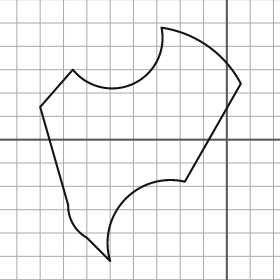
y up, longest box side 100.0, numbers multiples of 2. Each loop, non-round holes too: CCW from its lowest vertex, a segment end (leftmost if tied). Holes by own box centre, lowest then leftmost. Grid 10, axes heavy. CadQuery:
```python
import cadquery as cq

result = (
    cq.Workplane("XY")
    .moveTo(-50.0, -52.0)
    .threePointArc((-44.0, -26.0), (-18.0, -18.0))
    .lineTo(6.0, 24.0)
    .threePointArc((-8.0, 40.0), (-28.0, 48.0))
    .threePointArc((-40.0, 24.0), (-66.0, 30.0))
    .lineTo(-80.0, 14.0)
    .lineTo(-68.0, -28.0)
    .threePointArc((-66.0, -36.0), (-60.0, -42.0))
    .close()
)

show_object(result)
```